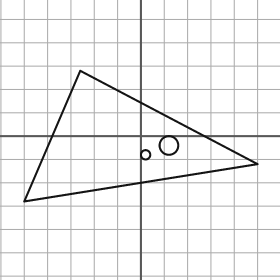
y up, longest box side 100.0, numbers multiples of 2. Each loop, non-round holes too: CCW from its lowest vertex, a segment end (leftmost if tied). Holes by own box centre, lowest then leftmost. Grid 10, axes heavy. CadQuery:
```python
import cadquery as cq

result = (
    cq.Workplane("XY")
    .moveTo(-50.0, -28.0)
    .lineTo(50.0, -12.0)
    .lineTo(-26.0, 28.0)
    .close()
    .moveTo(2.0, -8.0)
    .circle(2.0)
    .moveTo(12.0, -4.0)
    .circle(4.0)
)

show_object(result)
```